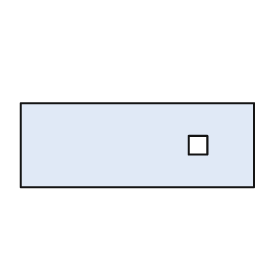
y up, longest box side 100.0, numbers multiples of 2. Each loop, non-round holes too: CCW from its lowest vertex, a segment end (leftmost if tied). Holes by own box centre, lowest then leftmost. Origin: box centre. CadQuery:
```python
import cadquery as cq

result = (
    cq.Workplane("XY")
    .moveTo(-50.0, -18.0)
    .lineTo(50.0, -18.0)
    .lineTo(50.0, 18.0)
    .lineTo(-50.0, 18.0)
    .close()
    .moveTo(22.0, -4.0)
    .lineTo(30.0, -4.0)
    .lineTo(30.0, 4.0)
    .lineTo(22.0, 4.0)
    .close()
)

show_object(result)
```